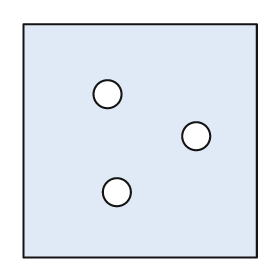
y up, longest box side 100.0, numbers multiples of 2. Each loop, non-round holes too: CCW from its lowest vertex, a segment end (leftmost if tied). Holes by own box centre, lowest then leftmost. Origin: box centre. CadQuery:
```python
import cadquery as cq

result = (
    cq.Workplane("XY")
    .moveTo(-50.0, -50.0)
    .lineTo(50.0, -50.0)
    .lineTo(50.0, 50.0)
    .lineTo(-50.0, 50.0)
    .close()
    .moveTo(-10.0, -22.0)
    .circle(6.0)
    .moveTo(24.0, 2.0)
    .circle(6.0)
    .moveTo(-14.0, 20.0)
    .circle(6.0)
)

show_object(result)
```